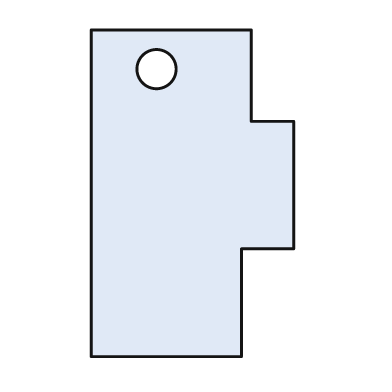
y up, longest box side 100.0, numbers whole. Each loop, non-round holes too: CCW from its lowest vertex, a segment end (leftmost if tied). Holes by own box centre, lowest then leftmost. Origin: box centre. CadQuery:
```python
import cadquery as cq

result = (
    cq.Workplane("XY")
    .moveTo(-31.0, -50.0)
    .lineTo(15.0, -50.0)
    .lineTo(15.0, -17.0)
    .lineTo(31.0, -17.0)
    .lineTo(31.0, 22.0)
    .lineTo(18.0, 22.0)
    .lineTo(18.0, 50.0)
    .lineTo(-31.0, 50.0)
    .close()
    .moveTo(-11.0, 38.0)
    .circle(6.0)
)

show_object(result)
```